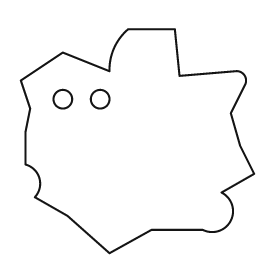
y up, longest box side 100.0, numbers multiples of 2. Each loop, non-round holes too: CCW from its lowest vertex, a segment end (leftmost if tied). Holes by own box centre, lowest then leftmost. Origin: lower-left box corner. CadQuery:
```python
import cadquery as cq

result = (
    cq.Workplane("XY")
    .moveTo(38.0, 0.0)
    .lineTo(56.0, 10.0)
    .lineTo(78.0, 10.0)
    .threePointArc((90.0, 14.0), (86.0, 26.0))
    .lineTo(100.0, 34.0)
    .lineTo(94.0, 46.0)
    .lineTo(90.0, 60.0)
    .lineTo(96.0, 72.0)
    .threePointArc((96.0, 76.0), (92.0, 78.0))
    .lineTo(68.0, 76.0)
    .lineTo(66.0, 96.0)
    .lineTo(46.0, 96.0)
    .threePointArc((40.0, 88.0), (38.0, 78.0))
    .lineTo(18.0, 86.0)
    .lineTo(0.0, 74.0)
    .lineTo(4.0, 62.0)
    .lineTo(2.0, 52.0)
    .lineTo(2.0, 38.0)
    .threePointArc((8.0, 32.0), (6.0, 24.0))
    .lineTo(20.0, 16.0)
    .close()
    .moveTo(18.0, 66.0)
    .circle(4.0)
    .moveTo(34.0, 66.0)
    .circle(4.0)
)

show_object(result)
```